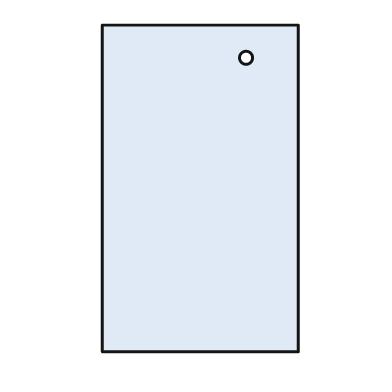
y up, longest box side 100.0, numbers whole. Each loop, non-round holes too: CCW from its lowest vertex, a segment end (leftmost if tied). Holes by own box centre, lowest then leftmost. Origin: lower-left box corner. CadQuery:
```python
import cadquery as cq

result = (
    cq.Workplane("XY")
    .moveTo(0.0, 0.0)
    .lineTo(60.0, 0.0)
    .lineTo(60.0, 100.0)
    .lineTo(0.0, 100.0)
    .close()
    .moveTo(44.0, 90.0)
    .circle(2.0)
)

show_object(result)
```